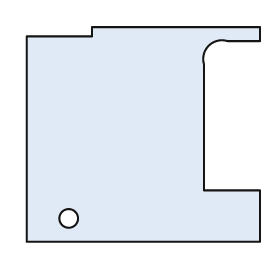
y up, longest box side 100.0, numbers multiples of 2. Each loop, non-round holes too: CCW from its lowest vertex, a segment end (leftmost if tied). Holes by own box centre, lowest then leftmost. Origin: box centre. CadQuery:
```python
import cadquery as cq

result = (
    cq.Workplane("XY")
    .moveTo(-50.0, -46.0)
    .lineTo(50.0, -46.0)
    .lineTo(50.0, -24.0)
    .lineTo(26.0, -24.0)
    .lineTo(26.0, 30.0)
    .threePointArc((28.0, 38.0), (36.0, 40.0))
    .lineTo(50.0, 40.0)
    .lineTo(50.0, 46.0)
    .lineTo(-22.0, 46.0)
    .lineTo(-22.0, 42.0)
    .lineTo(-50.0, 42.0)
    .close()
    .moveTo(-32.0, -36.0)
    .circle(4.0)
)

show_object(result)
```